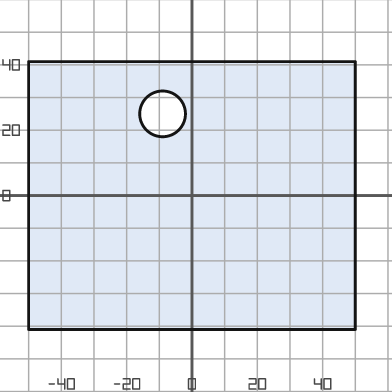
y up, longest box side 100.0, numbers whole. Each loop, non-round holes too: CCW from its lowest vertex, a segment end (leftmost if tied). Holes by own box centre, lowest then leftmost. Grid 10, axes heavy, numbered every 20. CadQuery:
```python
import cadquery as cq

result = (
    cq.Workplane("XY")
    .moveTo(-50.0, -41.0)
    .lineTo(50.0, -41.0)
    .lineTo(50.0, 41.0)
    .lineTo(-50.0, 41.0)
    .close()
    .moveTo(-9.0, 25.0)
    .circle(7.0)
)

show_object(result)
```